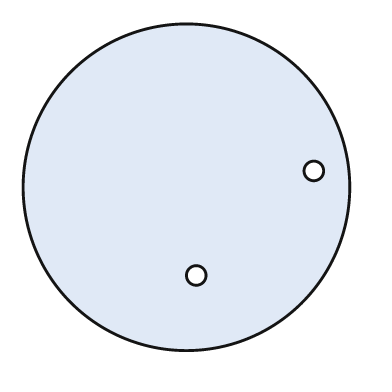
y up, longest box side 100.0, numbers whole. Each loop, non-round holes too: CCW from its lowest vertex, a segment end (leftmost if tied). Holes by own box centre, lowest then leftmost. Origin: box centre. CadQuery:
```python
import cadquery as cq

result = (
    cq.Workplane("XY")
    .moveTo(0.0, 0.0)
    .circle(50.0)
    .moveTo(3.0, -27.0)
    .circle(3.0)
    .moveTo(39.0, 5.0)
    .circle(3.0)
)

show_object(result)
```